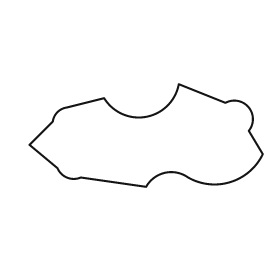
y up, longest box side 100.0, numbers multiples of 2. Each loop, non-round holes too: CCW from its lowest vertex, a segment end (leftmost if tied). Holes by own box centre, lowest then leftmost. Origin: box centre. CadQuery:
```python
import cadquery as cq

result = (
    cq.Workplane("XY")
    .moveTo(0.0, -22.0)
    .threePointArc((8.0, -16.0), (18.0, -18.0))
    .threePointArc((36.0, -20.0), (50.0, -8.0))
    .lineTo(44.0, 2.0)
    .threePointArc((44.0, 12.0), (34.0, 14.0))
    .lineTo(14.0, 22.0)
    .threePointArc((0.0, 8.0), (-18.0, 16.0))
    .lineTo(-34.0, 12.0)
    .threePointArc((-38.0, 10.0), (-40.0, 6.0))
    .lineTo(-50.0, -4.0)
    .lineTo(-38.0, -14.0)
    .threePointArc((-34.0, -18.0), (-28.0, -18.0))
    .close()
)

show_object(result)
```